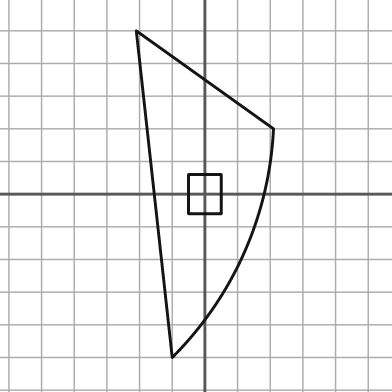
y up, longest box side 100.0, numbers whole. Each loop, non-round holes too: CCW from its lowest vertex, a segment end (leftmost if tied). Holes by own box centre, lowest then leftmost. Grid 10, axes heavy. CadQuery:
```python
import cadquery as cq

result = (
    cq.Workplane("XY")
    .moveTo(-10.0, -50.0)
    .threePointArc((12.0, -18.0), (21.0, 20.0))
    .lineTo(-21.0, 50.0)
    .close()
    .moveTo(-5.0, -6.0)
    .lineTo(5.0, -6.0)
    .lineTo(5.0, 6.0)
    .lineTo(-5.0, 6.0)
    .close()
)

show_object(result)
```